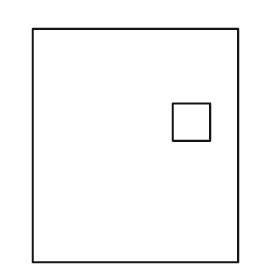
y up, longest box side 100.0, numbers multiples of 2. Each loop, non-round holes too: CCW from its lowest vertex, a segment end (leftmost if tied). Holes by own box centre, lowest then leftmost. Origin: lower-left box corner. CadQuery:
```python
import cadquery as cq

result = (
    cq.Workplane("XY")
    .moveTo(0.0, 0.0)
    .lineTo(88.0, 0.0)
    .lineTo(88.0, 100.0)
    .lineTo(0.0, 100.0)
    .close()
    .moveTo(60.0, 52.0)
    .lineTo(76.0, 52.0)
    .lineTo(76.0, 68.0)
    .lineTo(60.0, 68.0)
    .close()
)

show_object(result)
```